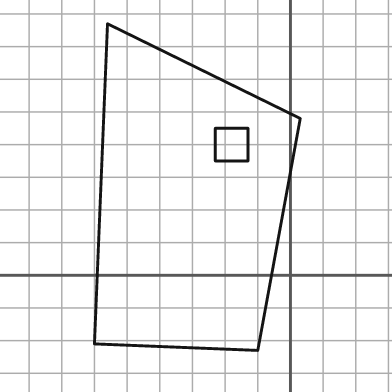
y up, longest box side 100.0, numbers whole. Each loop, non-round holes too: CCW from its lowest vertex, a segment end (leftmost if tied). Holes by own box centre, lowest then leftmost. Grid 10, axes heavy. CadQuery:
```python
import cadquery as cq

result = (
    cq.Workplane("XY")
    .moveTo(-10.0, -23.0)
    .lineTo(3.0, 48.0)
    .lineTo(-56.0, 77.0)
    .lineTo(-60.0, -21.0)
    .close()
    .moveTo(-23.0, 35.0)
    .lineTo(-13.0, 35.0)
    .lineTo(-13.0, 45.0)
    .lineTo(-23.0, 45.0)
    .close()
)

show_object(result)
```